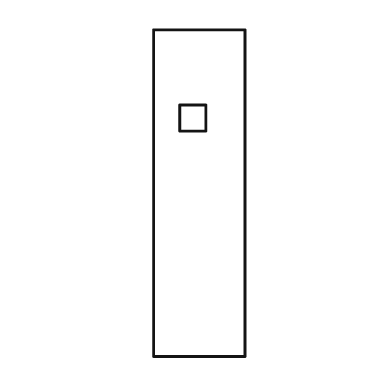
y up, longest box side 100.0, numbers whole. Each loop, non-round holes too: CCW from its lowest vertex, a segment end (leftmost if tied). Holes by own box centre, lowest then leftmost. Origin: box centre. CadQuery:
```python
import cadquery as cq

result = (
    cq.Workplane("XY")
    .moveTo(-14.0, -50.0)
    .lineTo(14.0, -50.0)
    .lineTo(14.0, 50.0)
    .lineTo(-14.0, 50.0)
    .close()
    .moveTo(-6.0, 19.0)
    .lineTo(2.0, 19.0)
    .lineTo(2.0, 27.0)
    .lineTo(-6.0, 27.0)
    .close()
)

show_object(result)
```